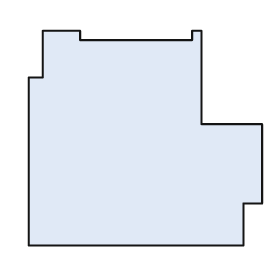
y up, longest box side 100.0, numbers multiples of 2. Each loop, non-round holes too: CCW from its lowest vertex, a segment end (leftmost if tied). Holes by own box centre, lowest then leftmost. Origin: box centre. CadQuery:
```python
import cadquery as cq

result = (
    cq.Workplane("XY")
    .moveTo(-50.0, -46.0)
    .lineTo(42.0, -46.0)
    .lineTo(42.0, -28.0)
    .lineTo(50.0, -28.0)
    .lineTo(50.0, 6.0)
    .lineTo(24.0, 6.0)
    .lineTo(24.0, 46.0)
    .lineTo(20.0, 46.0)
    .lineTo(20.0, 42.0)
    .lineTo(-28.0, 42.0)
    .lineTo(-28.0, 46.0)
    .lineTo(-44.0, 46.0)
    .lineTo(-44.0, 26.0)
    .lineTo(-50.0, 26.0)
    .close()
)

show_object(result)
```